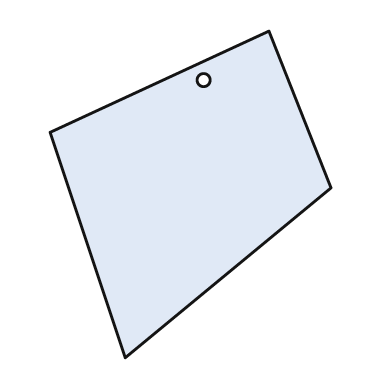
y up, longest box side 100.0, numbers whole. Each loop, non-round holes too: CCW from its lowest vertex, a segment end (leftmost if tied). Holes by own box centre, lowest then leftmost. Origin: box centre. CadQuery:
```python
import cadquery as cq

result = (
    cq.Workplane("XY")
    .moveTo(-20.0, -50.0)
    .lineTo(43.0, 2.0)
    .lineTo(24.0, 50.0)
    .lineTo(-43.0, 19.0)
    .close()
    .moveTo(4.0, 35.0)
    .circle(2.0)
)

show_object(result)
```